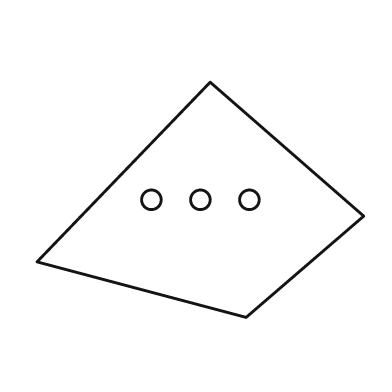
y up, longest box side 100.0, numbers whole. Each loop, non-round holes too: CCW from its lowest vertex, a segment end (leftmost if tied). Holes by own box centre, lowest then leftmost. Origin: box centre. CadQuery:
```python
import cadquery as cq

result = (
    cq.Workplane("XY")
    .moveTo(14.0, -36.0)
    .lineTo(50.0, -5.0)
    .lineTo(3.0, 36.0)
    .lineTo(-50.0, -19.0)
    .close()
    .moveTo(-15.0, 0.0)
    .circle(3.0)
    .moveTo(0.0, 0.0)
    .circle(3.0)
    .moveTo(15.0, 0.0)
    .circle(3.0)
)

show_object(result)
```